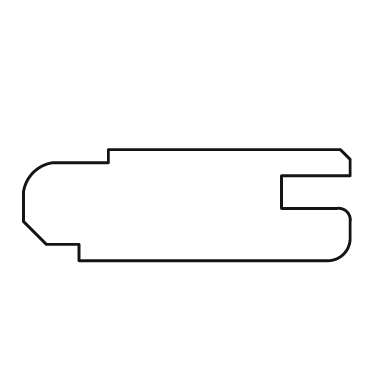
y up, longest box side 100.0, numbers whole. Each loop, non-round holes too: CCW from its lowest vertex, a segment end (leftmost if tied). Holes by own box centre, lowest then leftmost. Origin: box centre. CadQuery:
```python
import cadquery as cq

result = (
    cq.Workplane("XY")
    .moveTo(-33.0, -17.0)
    .lineTo(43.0, -17.0)
    .threePointArc((48.0, -15.0), (50.0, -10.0))
    .lineTo(50.0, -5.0)
    .threePointArc((49.0, -2.0), (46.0, -1.0))
    .lineTo(29.0, -1.0)
    .lineTo(29.0, 9.0)
    .lineTo(50.0, 9.0)
    .lineTo(50.0, 14.0)
    .lineTo(47.0, 17.0)
    .lineTo(-24.0, 17.0)
    .lineTo(-24.0, 13.0)
    .lineTo(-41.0, 13.0)
    .threePointArc((-47.0, 10.0), (-50.0, 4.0))
    .lineTo(-50.0, -5.0)
    .lineTo(-43.0, -12.0)
    .lineTo(-33.0, -12.0)
    .close()
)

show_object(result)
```